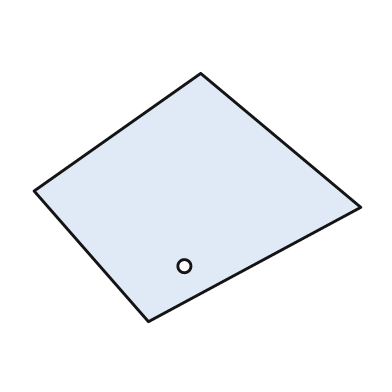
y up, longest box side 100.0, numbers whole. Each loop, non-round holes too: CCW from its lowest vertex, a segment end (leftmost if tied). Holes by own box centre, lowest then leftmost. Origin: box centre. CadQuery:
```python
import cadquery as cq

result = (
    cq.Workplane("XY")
    .moveTo(-15.0, -38.0)
    .lineTo(50.0, -3.0)
    .lineTo(1.0, 38.0)
    .lineTo(-50.0, 2.0)
    .close()
    .moveTo(-4.0, -21.0)
    .circle(2.0)
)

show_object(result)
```